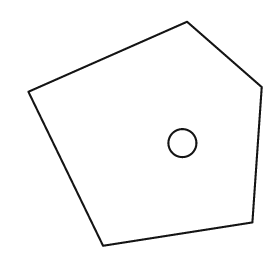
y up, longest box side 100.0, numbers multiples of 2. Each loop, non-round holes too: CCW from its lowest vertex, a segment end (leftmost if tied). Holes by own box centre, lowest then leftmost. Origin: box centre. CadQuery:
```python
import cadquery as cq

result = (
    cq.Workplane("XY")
    .moveTo(-18.0, -48.0)
    .lineTo(46.0, -38.0)
    .lineTo(50.0, 20.0)
    .lineTo(18.0, 48.0)
    .lineTo(-50.0, 18.0)
    .close()
    .moveTo(16.0, -4.0)
    .circle(6.0)
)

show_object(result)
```